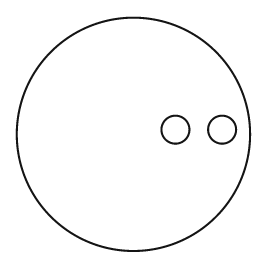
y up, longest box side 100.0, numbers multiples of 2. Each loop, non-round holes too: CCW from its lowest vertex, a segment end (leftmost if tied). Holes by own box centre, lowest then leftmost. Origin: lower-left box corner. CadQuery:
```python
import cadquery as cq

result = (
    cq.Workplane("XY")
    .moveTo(50.0, 50.0)
    .circle(50.0)
    .moveTo(68.0, 52.0)
    .circle(6.0)
    .moveTo(88.0, 52.0)
    .circle(6.0)
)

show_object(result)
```